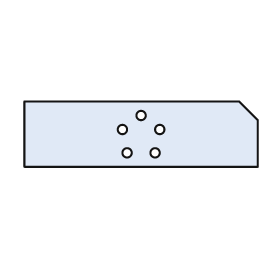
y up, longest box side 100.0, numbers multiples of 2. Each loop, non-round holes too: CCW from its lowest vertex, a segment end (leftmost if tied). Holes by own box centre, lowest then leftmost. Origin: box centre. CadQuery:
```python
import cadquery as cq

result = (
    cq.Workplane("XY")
    .moveTo(-50.0, -14.0)
    .lineTo(50.0, -14.0)
    .lineTo(50.0, 6.0)
    .lineTo(42.0, 14.0)
    .lineTo(-50.0, 14.0)
    .close()
    .moveTo(-6.0, -8.0)
    .circle(2.0)
    .moveTo(6.0, -8.0)
    .circle(2.0)
    .moveTo(-8.0, 2.0)
    .circle(2.0)
    .moveTo(8.0, 2.0)
    .circle(2.0)
    .moveTo(0.0, 8.0)
    .circle(2.0)
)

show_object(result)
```